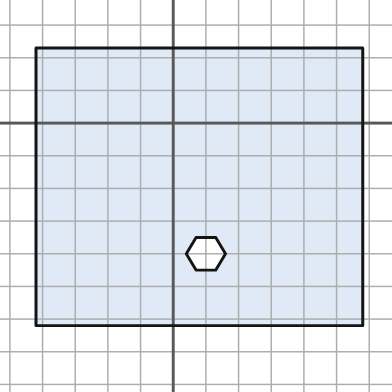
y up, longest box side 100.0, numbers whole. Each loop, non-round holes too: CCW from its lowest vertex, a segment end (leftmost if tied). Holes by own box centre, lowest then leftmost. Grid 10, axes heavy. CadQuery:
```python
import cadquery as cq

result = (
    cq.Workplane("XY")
    .moveTo(-42.0, -62.0)
    .lineTo(58.0, -62.0)
    .lineTo(58.0, 23.0)
    .lineTo(-42.0, 23.0)
    .close()
    .moveTo(7.0, -45.0)
    .lineTo(13.0, -45.0)
    .lineTo(16.0, -40.0)
    .lineTo(13.0, -35.0)
    .lineTo(7.0, -35.0)
    .lineTo(4.0, -40.0)
    .close()
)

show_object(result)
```